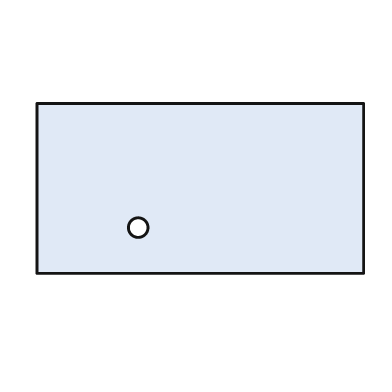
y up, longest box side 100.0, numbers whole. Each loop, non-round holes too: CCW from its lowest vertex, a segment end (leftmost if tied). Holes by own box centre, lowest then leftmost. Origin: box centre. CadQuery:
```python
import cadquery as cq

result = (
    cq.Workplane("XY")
    .moveTo(-50.0, -26.0)
    .lineTo(50.0, -26.0)
    .lineTo(50.0, 26.0)
    .lineTo(-50.0, 26.0)
    .close()
    .moveTo(-19.0, -12.0)
    .circle(3.0)
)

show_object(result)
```